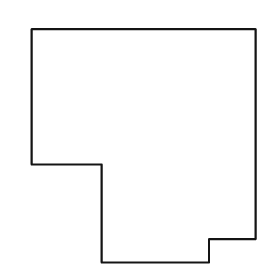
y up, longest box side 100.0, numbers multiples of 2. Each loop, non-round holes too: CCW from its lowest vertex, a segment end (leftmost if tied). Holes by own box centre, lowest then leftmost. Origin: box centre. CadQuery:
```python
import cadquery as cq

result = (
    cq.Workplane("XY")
    .moveTo(-18.0, -50.0)
    .lineTo(28.0, -50.0)
    .lineTo(28.0, -40.0)
    .lineTo(48.0, -40.0)
    .lineTo(48.0, 50.0)
    .lineTo(-48.0, 50.0)
    .lineTo(-48.0, -8.0)
    .lineTo(-18.0, -8.0)
    .close()
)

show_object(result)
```